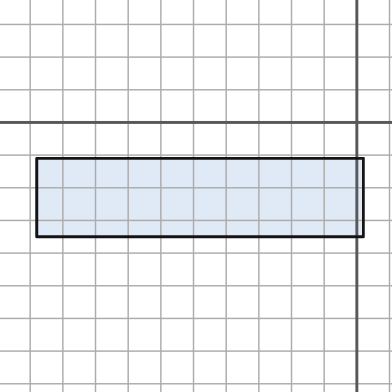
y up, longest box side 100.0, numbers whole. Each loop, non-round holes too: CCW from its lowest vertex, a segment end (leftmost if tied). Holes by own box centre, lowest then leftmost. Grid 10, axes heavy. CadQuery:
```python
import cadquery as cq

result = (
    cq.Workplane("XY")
    .moveTo(-98.0, -35.0)
    .lineTo(2.0, -35.0)
    .lineTo(2.0, -11.0)
    .lineTo(-98.0, -11.0)
    .close()
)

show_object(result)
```